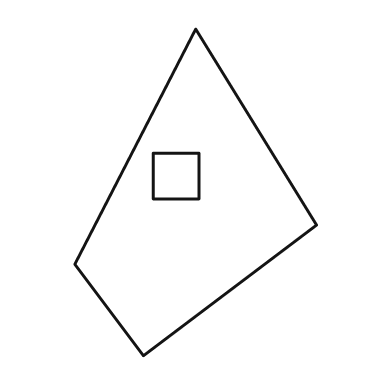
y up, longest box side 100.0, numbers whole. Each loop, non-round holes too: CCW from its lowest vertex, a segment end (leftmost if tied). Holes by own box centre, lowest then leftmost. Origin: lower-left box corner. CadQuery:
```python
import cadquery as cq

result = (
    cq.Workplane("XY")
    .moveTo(21.0, 0.0)
    .lineTo(74.0, 40.0)
    .lineTo(37.0, 100.0)
    .lineTo(0.0, 28.0)
    .close()
    .moveTo(24.0, 48.0)
    .lineTo(38.0, 48.0)
    .lineTo(38.0, 62.0)
    .lineTo(24.0, 62.0)
    .close()
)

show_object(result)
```